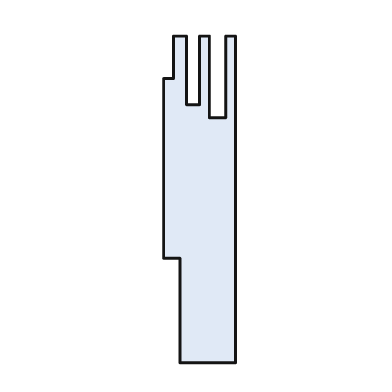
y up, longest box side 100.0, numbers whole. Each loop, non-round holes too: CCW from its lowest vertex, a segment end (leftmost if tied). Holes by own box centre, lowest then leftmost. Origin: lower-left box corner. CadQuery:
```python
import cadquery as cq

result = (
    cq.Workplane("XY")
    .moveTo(5.0, 0.0)
    .lineTo(22.0, 0.0)
    .lineTo(22.0, 100.0)
    .lineTo(19.0, 100.0)
    .lineTo(19.0, 75.0)
    .lineTo(14.0, 75.0)
    .lineTo(14.0, 100.0)
    .lineTo(11.0, 100.0)
    .lineTo(11.0, 79.0)
    .lineTo(7.0, 79.0)
    .lineTo(7.0, 100.0)
    .lineTo(3.0, 100.0)
    .lineTo(3.0, 87.0)
    .lineTo(0.0, 87.0)
    .lineTo(0.0, 32.0)
    .lineTo(5.0, 32.0)
    .close()
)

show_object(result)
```